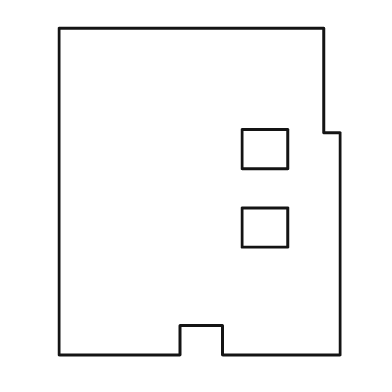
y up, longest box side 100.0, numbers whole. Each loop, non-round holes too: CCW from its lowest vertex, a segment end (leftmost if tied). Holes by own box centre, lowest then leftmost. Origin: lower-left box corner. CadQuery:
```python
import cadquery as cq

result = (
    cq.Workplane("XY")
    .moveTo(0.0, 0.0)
    .lineTo(37.0, 0.0)
    .lineTo(37.0, 9.0)
    .lineTo(50.0, 9.0)
    .lineTo(50.0, 0.0)
    .lineTo(86.0, 0.0)
    .lineTo(86.0, 68.0)
    .lineTo(81.0, 68.0)
    .lineTo(81.0, 100.0)
    .lineTo(0.0, 100.0)
    .close()
    .moveTo(56.0, 33.0)
    .lineTo(70.0, 33.0)
    .lineTo(70.0, 45.0)
    .lineTo(56.0, 45.0)
    .close()
    .moveTo(56.0, 57.0)
    .lineTo(70.0, 57.0)
    .lineTo(70.0, 69.0)
    .lineTo(56.0, 69.0)
    .close()
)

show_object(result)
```